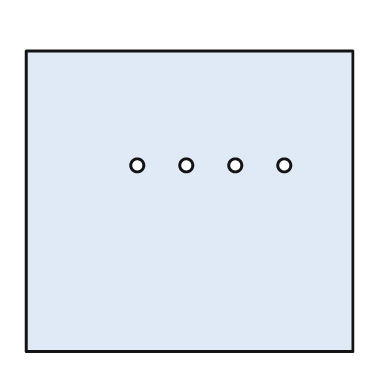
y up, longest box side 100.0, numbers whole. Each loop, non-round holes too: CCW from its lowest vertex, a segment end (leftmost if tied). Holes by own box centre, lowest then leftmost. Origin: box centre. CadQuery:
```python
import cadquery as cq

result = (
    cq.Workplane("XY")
    .moveTo(-50.0, -46.0)
    .lineTo(50.0, -46.0)
    .lineTo(50.0, 46.0)
    .lineTo(-50.0, 46.0)
    .close()
    .moveTo(-16.0, 11.0)
    .circle(2.0)
    .moveTo(-1.0, 11.0)
    .circle(2.0)
    .moveTo(14.0, 11.0)
    .circle(2.0)
    .moveTo(29.0, 11.0)
    .circle(2.0)
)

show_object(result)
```